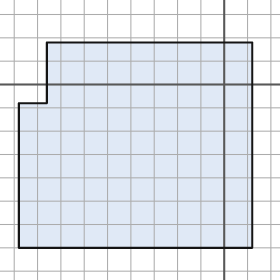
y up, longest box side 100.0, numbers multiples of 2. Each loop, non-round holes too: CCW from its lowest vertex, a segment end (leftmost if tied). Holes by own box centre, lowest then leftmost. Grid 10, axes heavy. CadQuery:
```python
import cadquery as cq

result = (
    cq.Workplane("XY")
    .moveTo(-88.0, -70.0)
    .lineTo(12.0, -70.0)
    .lineTo(12.0, 18.0)
    .lineTo(-76.0, 18.0)
    .lineTo(-76.0, -8.0)
    .lineTo(-88.0, -8.0)
    .close()
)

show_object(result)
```